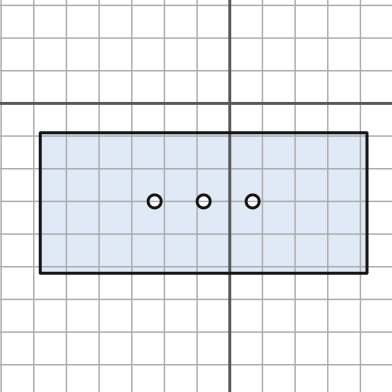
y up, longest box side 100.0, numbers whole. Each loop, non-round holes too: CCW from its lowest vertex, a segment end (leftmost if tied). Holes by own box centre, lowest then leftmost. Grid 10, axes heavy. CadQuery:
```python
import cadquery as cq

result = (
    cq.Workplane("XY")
    .moveTo(-58.0, -52.0)
    .lineTo(42.0, -52.0)
    .lineTo(42.0, -9.0)
    .lineTo(-58.0, -9.0)
    .close()
    .moveTo(-23.0, -30.0)
    .circle(2.0)
    .moveTo(-8.0, -30.0)
    .circle(2.0)
    .moveTo(7.0, -30.0)
    .circle(2.0)
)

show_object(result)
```